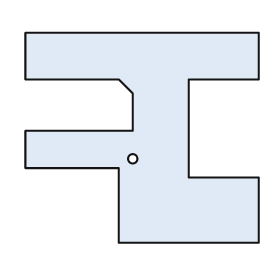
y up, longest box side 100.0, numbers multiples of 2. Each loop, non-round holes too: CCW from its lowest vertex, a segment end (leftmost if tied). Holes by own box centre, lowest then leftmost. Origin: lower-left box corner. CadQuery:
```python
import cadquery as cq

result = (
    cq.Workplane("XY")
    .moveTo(40.0, 0.0)
    .lineTo(100.0, 0.0)
    .lineTo(100.0, 28.0)
    .lineTo(70.0, 28.0)
    .lineTo(70.0, 70.0)
    .lineTo(100.0, 70.0)
    .lineTo(100.0, 90.0)
    .lineTo(0.0, 90.0)
    .lineTo(0.0, 70.0)
    .lineTo(40.0, 70.0)
    .lineTo(46.0, 64.0)
    .lineTo(46.0, 48.0)
    .lineTo(0.0, 48.0)
    .lineTo(0.0, 32.0)
    .lineTo(40.0, 32.0)
    .close()
    .moveTo(46.0, 36.0)
    .circle(2.0)
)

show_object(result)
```